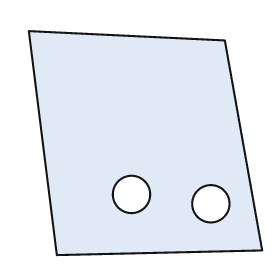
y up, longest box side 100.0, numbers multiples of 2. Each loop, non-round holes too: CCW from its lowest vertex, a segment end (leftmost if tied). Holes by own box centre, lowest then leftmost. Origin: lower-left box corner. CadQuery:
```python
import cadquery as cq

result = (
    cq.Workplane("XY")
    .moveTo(12.0, 0.0)
    .lineTo(100.0, 2.0)
    .lineTo(84.0, 92.0)
    .lineTo(0.0, 96.0)
    .close()
    .moveTo(78.0, 22.0)
    .circle(8.0)
    .moveTo(44.0, 26.0)
    .circle(8.0)
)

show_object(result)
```